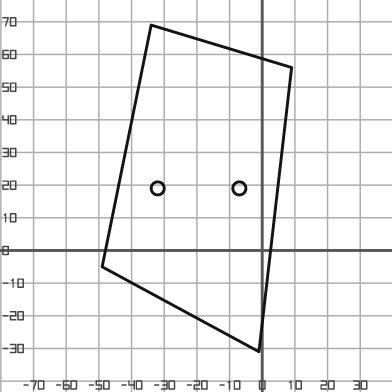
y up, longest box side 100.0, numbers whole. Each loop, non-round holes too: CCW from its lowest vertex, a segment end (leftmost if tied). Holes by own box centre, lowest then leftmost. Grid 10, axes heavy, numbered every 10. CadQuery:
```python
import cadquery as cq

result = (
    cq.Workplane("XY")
    .moveTo(-1.0, -31.0)
    .lineTo(9.0, 56.0)
    .lineTo(-34.0, 69.0)
    .lineTo(-49.0, -5.0)
    .close()
    .moveTo(-32.0, 19.0)
    .circle(2.0)
    .moveTo(-7.0, 19.0)
    .circle(2.0)
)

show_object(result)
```